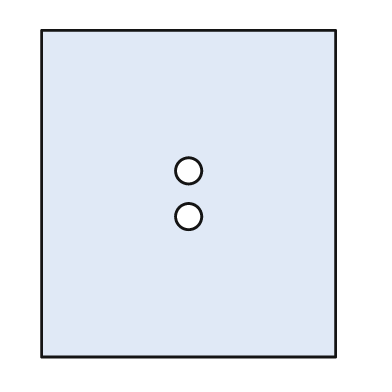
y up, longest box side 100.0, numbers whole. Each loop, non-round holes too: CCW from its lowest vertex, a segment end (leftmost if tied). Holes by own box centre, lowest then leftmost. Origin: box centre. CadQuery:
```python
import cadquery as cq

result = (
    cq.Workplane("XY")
    .moveTo(-45.0, -50.0)
    .lineTo(45.0, -50.0)
    .lineTo(45.0, 50.0)
    .lineTo(-45.0, 50.0)
    .close()
    .moveTo(0.0, -7.0)
    .circle(4.0)
    .moveTo(0.0, 7.0)
    .circle(4.0)
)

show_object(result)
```